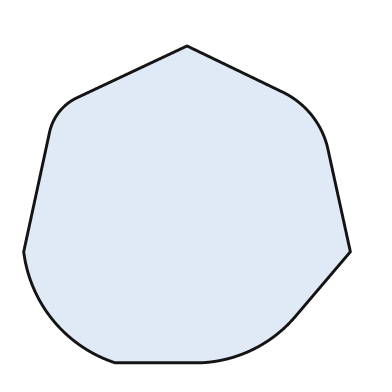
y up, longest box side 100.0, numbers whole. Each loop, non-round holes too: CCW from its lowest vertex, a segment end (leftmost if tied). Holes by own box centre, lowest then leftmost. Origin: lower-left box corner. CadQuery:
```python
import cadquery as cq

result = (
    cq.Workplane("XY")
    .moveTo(28.0, 0.0)
    .lineTo(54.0, 0.0)
    .threePointArc((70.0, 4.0), (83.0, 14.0))
    .lineTo(100.0, 34.0)
    .lineTo(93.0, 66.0)
    .threePointArc((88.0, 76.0), (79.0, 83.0))
    .lineTo(50.0, 97.0)
    .lineTo(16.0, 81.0)
    .threePointArc((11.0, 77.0), (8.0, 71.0))
    .lineTo(0.0, 34.0)
    .threePointArc((9.0, 13.0), (28.0, 0.0))
    .close()
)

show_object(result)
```